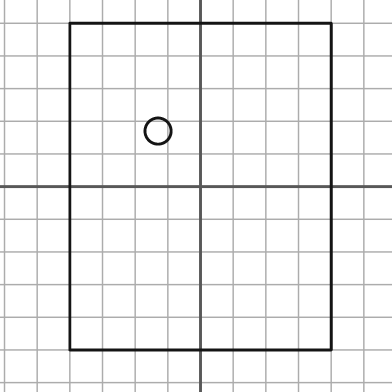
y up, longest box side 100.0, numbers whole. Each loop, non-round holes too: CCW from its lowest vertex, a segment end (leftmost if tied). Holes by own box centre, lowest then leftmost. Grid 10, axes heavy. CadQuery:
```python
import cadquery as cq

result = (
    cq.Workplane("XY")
    .moveTo(-40.0, -50.0)
    .lineTo(40.0, -50.0)
    .lineTo(40.0, 50.0)
    .lineTo(-40.0, 50.0)
    .close()
    .moveTo(-13.0, 17.0)
    .circle(4.0)
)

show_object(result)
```